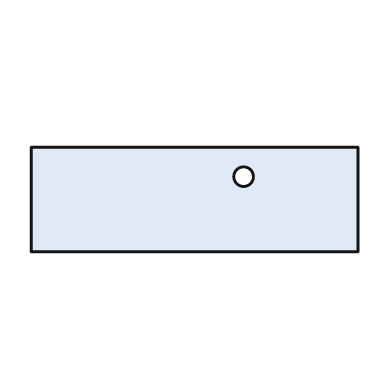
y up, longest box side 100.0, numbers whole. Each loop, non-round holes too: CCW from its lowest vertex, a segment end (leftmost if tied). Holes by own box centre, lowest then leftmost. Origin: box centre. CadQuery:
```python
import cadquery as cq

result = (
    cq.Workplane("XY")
    .moveTo(-50.0, -16.0)
    .lineTo(50.0, -16.0)
    .lineTo(50.0, 16.0)
    .lineTo(-50.0, 16.0)
    .close()
    .moveTo(15.0, 7.0)
    .circle(3.0)
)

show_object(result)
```